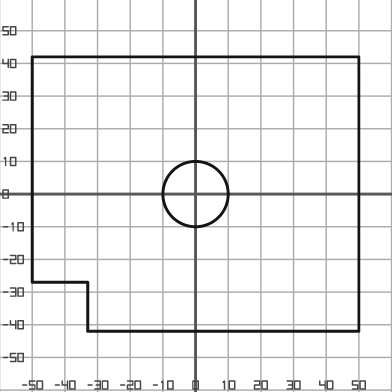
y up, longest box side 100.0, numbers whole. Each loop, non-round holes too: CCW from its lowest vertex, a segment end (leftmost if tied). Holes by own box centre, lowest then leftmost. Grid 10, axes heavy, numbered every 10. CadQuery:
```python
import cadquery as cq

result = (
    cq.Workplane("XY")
    .moveTo(-33.0, -42.0)
    .lineTo(50.0, -42.0)
    .lineTo(50.0, 42.0)
    .lineTo(-50.0, 42.0)
    .lineTo(-50.0, -27.0)
    .lineTo(-33.0, -27.0)
    .close()
    .moveTo(0.0, 0.0)
    .circle(10.0)
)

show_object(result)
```